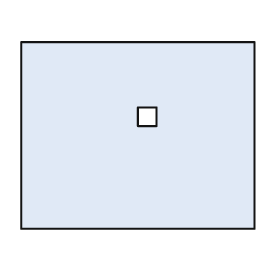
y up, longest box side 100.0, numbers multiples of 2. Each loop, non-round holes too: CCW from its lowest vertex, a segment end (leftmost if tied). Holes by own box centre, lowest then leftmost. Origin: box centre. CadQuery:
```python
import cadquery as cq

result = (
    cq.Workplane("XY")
    .moveTo(-50.0, -40.0)
    .lineTo(50.0, -40.0)
    .lineTo(50.0, 40.0)
    .lineTo(-50.0, 40.0)
    .close()
    .moveTo(0.0, 4.0)
    .lineTo(8.0, 4.0)
    .lineTo(8.0, 12.0)
    .lineTo(0.0, 12.0)
    .close()
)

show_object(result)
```